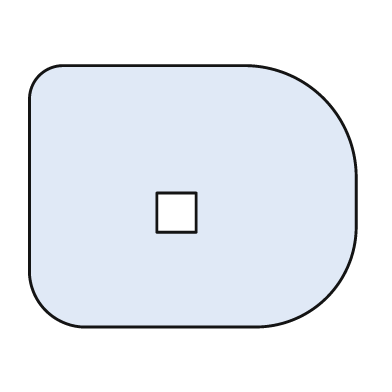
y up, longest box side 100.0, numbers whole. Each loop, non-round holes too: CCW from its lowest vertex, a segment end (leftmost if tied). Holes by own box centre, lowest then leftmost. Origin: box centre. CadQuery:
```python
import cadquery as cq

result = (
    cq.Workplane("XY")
    .moveTo(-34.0, -40.0)
    .lineTo(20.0, -40.0)
    .threePointArc((41.0, -31.0), (50.0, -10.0))
    .lineTo(50.0, 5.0)
    .threePointArc((40.0, 30.0), (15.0, 40.0))
    .lineTo(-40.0, 40.0)
    .threePointArc((-47.0, 37.0), (-50.0, 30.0))
    .lineTo(-50.0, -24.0)
    .threePointArc((-45.0, -35.0), (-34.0, -40.0))
    .close()
    .moveTo(-11.0, -11.0)
    .lineTo(1.0, -11.0)
    .lineTo(1.0, 1.0)
    .lineTo(-11.0, 1.0)
    .close()
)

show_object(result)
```